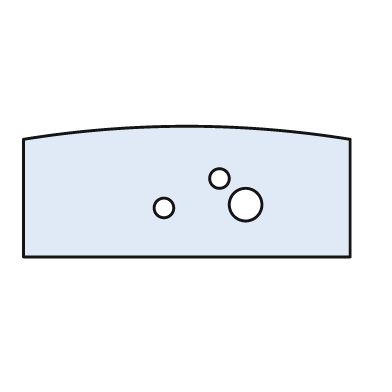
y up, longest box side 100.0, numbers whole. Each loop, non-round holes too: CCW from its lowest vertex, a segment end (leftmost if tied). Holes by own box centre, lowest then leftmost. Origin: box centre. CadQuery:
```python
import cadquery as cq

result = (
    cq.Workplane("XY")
    .moveTo(-50.0, -20.0)
    .lineTo(50.0, -20.0)
    .lineTo(50.0, 16.0)
    .threePointArc((0.0, 20.0), (-50.0, 16.0))
    .close()
    .moveTo(-7.0, -5.0)
    .circle(3.0)
    .moveTo(18.0, -4.0)
    .circle(5.0)
    .moveTo(10.0, 4.0)
    .circle(3.0)
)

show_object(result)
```